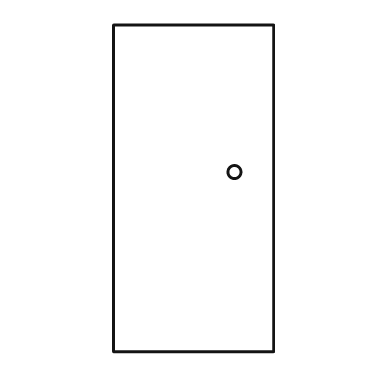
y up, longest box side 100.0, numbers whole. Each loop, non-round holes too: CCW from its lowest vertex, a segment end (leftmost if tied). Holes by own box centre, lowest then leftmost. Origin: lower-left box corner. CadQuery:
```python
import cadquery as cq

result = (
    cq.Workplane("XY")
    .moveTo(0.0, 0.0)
    .lineTo(49.0, 0.0)
    .lineTo(49.0, 100.0)
    .lineTo(0.0, 100.0)
    .close()
    .moveTo(37.0, 55.0)
    .circle(2.0)
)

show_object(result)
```